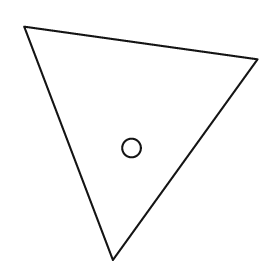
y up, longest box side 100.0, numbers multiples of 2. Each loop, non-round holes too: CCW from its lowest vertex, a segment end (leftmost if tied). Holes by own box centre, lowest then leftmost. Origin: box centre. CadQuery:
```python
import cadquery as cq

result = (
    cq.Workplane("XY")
    .moveTo(-12.0, -50.0)
    .lineTo(50.0, 36.0)
    .lineTo(-50.0, 50.0)
    .close()
    .moveTo(-4.0, -2.0)
    .circle(4.0)
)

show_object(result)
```